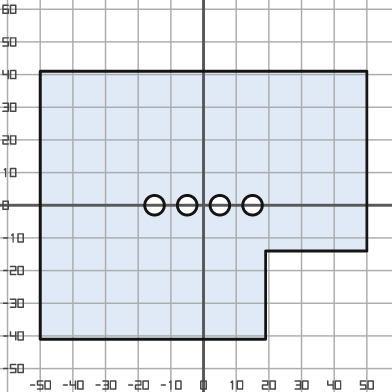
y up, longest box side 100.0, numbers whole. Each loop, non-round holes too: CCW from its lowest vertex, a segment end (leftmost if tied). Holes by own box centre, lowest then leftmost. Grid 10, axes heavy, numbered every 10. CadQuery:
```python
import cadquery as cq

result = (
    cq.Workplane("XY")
    .moveTo(-50.0, -41.0)
    .lineTo(19.0, -41.0)
    .lineTo(19.0, -14.0)
    .lineTo(50.0, -14.0)
    .lineTo(50.0, 41.0)
    .lineTo(-50.0, 41.0)
    .close()
    .moveTo(-15.0, 0.0)
    .circle(3.0)
    .moveTo(-5.0, 0.0)
    .circle(3.0)
    .moveTo(5.0, 0.0)
    .circle(3.0)
    .moveTo(15.0, 0.0)
    .circle(3.0)
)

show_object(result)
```